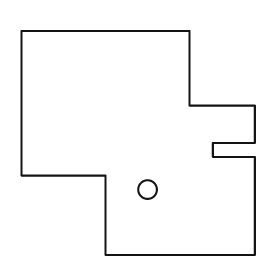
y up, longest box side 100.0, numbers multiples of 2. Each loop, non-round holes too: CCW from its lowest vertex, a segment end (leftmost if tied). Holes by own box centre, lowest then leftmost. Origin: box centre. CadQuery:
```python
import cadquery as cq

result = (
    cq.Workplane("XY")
    .moveTo(-14.0, -48.0)
    .lineTo(50.0, -48.0)
    .lineTo(50.0, -6.0)
    .lineTo(32.0, -6.0)
    .lineTo(32.0, 0.0)
    .lineTo(50.0, 0.0)
    .lineTo(50.0, 16.0)
    .lineTo(22.0, 16.0)
    .lineTo(22.0, 48.0)
    .lineTo(-50.0, 48.0)
    .lineTo(-50.0, -14.0)
    .lineTo(-14.0, -14.0)
    .close()
    .moveTo(4.0, -20.0)
    .circle(4.0)
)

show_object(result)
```